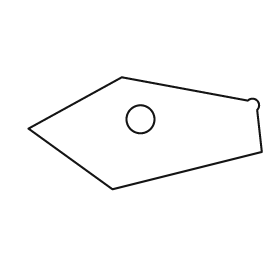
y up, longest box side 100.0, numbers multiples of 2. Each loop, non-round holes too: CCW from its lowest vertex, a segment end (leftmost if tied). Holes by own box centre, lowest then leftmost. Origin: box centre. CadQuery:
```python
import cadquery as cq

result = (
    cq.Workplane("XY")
    .moveTo(-14.0, -24.0)
    .lineTo(50.0, -8.0)
    .lineTo(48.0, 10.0)
    .threePointArc((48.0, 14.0), (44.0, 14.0))
    .lineTo(-10.0, 24.0)
    .lineTo(-50.0, 2.0)
    .close()
    .moveTo(-2.0, 6.0)
    .circle(6.0)
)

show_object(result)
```